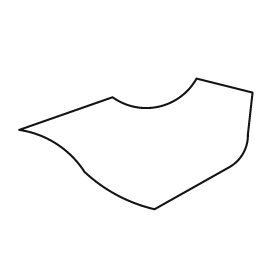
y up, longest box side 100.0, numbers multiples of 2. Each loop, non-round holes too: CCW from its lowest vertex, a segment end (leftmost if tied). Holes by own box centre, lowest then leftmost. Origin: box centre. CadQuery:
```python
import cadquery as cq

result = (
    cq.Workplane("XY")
    .moveTo(8.0, -28.0)
    .lineTo(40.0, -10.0)
    .threePointArc((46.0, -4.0), (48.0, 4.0))
    .lineTo(50.0, 22.0)
    .lineTo(26.0, 28.0)
    .threePointArc((10.0, 16.0), (-10.0, 20.0))
    .lineTo(-50.0, 6.0)
    .threePointArc((-34.0, 0.0), (-22.0, -12.0))
    .threePointArc((-8.0, -22.0), (8.0, -28.0))
    .close()
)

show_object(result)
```